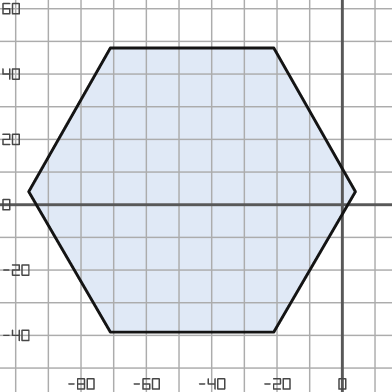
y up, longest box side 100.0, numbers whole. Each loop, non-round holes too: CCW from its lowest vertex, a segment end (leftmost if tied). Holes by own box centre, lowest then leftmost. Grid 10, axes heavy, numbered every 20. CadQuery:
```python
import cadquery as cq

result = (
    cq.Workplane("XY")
    .moveTo(-71.0, -39.0)
    .lineTo(-21.0, -39.0)
    .lineTo(4.0, 4.0)
    .lineTo(-21.0, 48.0)
    .lineTo(-71.0, 48.0)
    .lineTo(-96.0, 4.0)
    .close()
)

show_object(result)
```